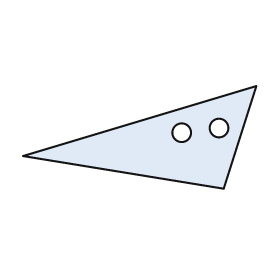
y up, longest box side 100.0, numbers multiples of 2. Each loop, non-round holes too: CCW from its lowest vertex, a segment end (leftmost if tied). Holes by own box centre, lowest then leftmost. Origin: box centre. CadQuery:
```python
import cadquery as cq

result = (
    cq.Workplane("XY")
    .moveTo(36.0, -22.0)
    .lineTo(50.0, 22.0)
    .lineTo(-50.0, -8.0)
    .close()
    .moveTo(18.0, 2.0)
    .circle(4.0)
    .moveTo(34.0, 4.0)
    .circle(4.0)
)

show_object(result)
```